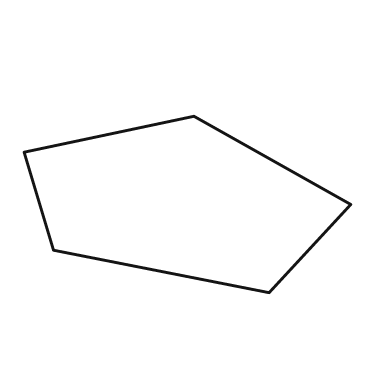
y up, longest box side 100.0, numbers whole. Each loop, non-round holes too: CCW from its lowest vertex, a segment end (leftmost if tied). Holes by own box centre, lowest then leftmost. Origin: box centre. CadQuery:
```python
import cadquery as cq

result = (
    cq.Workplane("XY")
    .moveTo(25.0, -27.0)
    .lineTo(50.0, 0.0)
    .lineTo(2.0, 27.0)
    .lineTo(-50.0, 16.0)
    .lineTo(-41.0, -14.0)
    .close()
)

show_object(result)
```